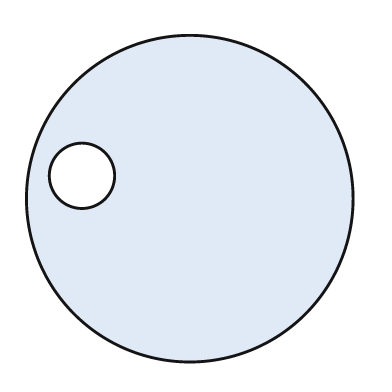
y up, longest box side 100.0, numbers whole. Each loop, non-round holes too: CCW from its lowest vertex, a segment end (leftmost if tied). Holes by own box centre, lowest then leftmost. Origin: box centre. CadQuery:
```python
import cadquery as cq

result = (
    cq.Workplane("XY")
    .moveTo(0.0, 0.0)
    .circle(50.0)
    .moveTo(-33.0, 7.0)
    .circle(10.0)
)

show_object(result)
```